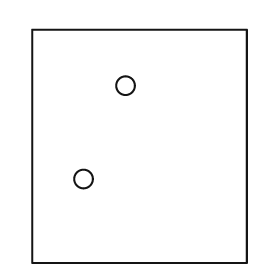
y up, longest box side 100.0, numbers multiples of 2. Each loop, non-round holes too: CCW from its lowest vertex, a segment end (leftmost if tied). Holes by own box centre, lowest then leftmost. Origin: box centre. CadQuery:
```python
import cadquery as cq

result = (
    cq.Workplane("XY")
    .moveTo(-46.0, -50.0)
    .lineTo(46.0, -50.0)
    .lineTo(46.0, 50.0)
    .lineTo(-46.0, 50.0)
    .close()
    .moveTo(-24.0, -14.0)
    .circle(4.0)
    .moveTo(-6.0, 26.0)
    .circle(4.0)
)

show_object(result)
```